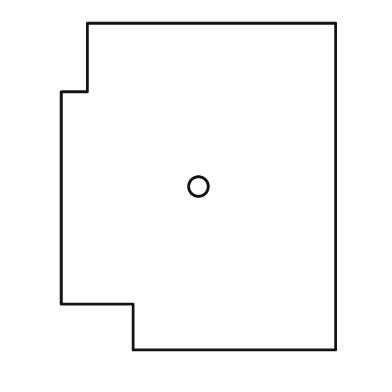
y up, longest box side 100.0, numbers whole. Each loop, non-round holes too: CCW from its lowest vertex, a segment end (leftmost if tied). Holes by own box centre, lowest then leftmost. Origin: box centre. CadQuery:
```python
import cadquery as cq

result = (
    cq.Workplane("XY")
    .moveTo(-20.0, -50.0)
    .lineTo(42.0, -50.0)
    .lineTo(42.0, 50.0)
    .lineTo(-34.0, 50.0)
    .lineTo(-34.0, 29.0)
    .lineTo(-42.0, 29.0)
    .lineTo(-42.0, -36.0)
    .lineTo(-20.0, -36.0)
    .close()
    .moveTo(0.0, 0.0)
    .circle(3.0)
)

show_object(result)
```